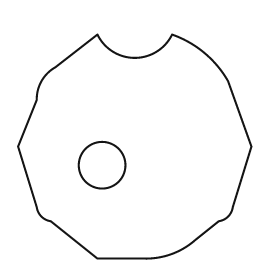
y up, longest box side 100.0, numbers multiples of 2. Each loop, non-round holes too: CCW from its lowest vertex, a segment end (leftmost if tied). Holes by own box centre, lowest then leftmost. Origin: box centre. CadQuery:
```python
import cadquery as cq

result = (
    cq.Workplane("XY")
    .moveTo(-16.0, -48.0)
    .lineTo(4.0, -48.0)
    .threePointArc((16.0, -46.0), (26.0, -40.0))
    .lineTo(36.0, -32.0)
    .threePointArc((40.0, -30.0), (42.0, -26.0))
    .lineTo(50.0, 0.0)
    .lineTo(40.0, 28.0)
    .threePointArc((30.0, 40.0), (16.0, 48.0))
    .threePointArc((0.0, 38.0), (-16.0, 48.0))
    .lineTo(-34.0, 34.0)
    .threePointArc((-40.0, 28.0), (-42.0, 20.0))
    .lineTo(-50.0, 0.0)
    .lineTo(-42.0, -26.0)
    .threePointArc((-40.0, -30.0), (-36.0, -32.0))
    .close()
    .moveTo(-14.0, -8.0)
    .circle(10.0)
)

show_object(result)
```